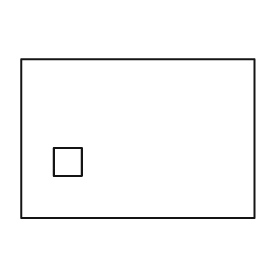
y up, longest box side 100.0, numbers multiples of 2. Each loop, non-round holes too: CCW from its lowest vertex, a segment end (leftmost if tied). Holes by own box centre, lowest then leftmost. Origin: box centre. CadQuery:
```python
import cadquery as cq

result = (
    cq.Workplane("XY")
    .moveTo(-50.0, -34.0)
    .lineTo(50.0, -34.0)
    .lineTo(50.0, 34.0)
    .lineTo(-50.0, 34.0)
    .close()
    .moveTo(-36.0, -16.0)
    .lineTo(-24.0, -16.0)
    .lineTo(-24.0, -4.0)
    .lineTo(-36.0, -4.0)
    .close()
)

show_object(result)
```